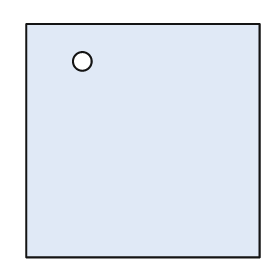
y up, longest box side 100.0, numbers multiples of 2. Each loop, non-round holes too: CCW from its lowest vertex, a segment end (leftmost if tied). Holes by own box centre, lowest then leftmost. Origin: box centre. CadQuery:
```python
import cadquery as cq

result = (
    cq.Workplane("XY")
    .moveTo(-50.0, -50.0)
    .lineTo(50.0, -50.0)
    .lineTo(50.0, 50.0)
    .lineTo(-50.0, 50.0)
    .close()
    .moveTo(-26.0, 34.0)
    .circle(4.0)
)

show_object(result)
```